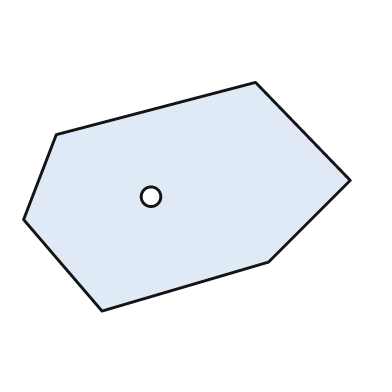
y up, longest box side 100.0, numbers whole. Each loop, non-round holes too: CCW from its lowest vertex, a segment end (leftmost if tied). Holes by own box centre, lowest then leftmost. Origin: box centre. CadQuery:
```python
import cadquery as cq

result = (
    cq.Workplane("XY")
    .moveTo(-26.0, -35.0)
    .lineTo(25.0, -20.0)
    .lineTo(50.0, 5.0)
    .lineTo(21.0, 35.0)
    .lineTo(-40.0, 19.0)
    .lineTo(-50.0, -7.0)
    .close()
    .moveTo(-11.0, 0.0)
    .circle(3.0)
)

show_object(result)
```